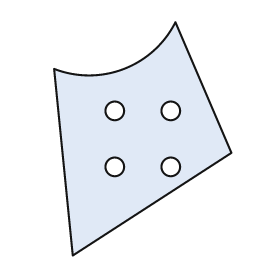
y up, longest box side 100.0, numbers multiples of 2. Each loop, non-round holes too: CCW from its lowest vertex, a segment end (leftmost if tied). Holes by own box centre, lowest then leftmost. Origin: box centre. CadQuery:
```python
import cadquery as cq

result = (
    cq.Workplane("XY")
    .moveTo(-30.0, -50.0)
    .lineTo(38.0, -6.0)
    .lineTo(14.0, 50.0)
    .threePointArc((-8.0, 30.0), (-38.0, 30.0))
    .close()
    .moveTo(-12.0, -12.0)
    .circle(4.0)
    .moveTo(12.0, -12.0)
    .circle(4.0)
    .moveTo(-12.0, 12.0)
    .circle(4.0)
    .moveTo(12.0, 12.0)
    .circle(4.0)
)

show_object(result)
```